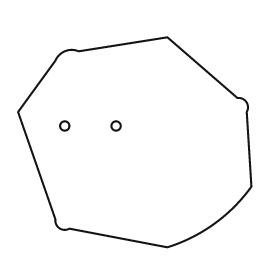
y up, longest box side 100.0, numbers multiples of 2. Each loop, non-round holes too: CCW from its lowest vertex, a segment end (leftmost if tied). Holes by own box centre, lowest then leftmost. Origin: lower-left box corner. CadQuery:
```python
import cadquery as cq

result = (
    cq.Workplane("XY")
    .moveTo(64.0, 0.0)
    .threePointArc((84.0, 10.0), (100.0, 26.0))
    .lineTo(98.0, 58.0)
    .threePointArc((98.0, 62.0), (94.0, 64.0))
    .lineTo(64.0, 90.0)
    .lineTo(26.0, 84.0)
    .threePointArc((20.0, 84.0), (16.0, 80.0))
    .lineTo(0.0, 58.0)
    .lineTo(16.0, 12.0)
    .threePointArc((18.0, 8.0), (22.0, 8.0))
    .close()
    .moveTo(20.0, 52.0)
    .circle(2.0)
    .moveTo(42.0, 52.0)
    .circle(2.0)
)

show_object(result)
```